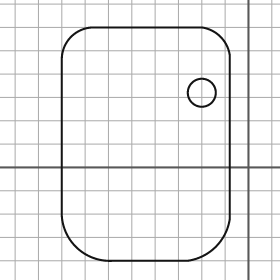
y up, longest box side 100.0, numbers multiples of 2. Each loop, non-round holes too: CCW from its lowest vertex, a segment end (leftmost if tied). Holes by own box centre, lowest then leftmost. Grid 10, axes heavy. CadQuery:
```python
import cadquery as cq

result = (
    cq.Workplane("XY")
    .moveTo(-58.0, -40.0)
    .lineTo(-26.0, -40.0)
    .threePointArc((-14.0, -34.0), (-8.0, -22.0))
    .lineTo(-8.0, 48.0)
    .threePointArc((-12.0, 56.0), (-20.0, 60.0))
    .lineTo(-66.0, 60.0)
    .threePointArc((-76.0, 56.0), (-80.0, 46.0))
    .lineTo(-80.0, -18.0)
    .threePointArc((-74.0, -34.0), (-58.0, -40.0))
    .close()
    .moveTo(-20.0, 32.0)
    .circle(6.0)
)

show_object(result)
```